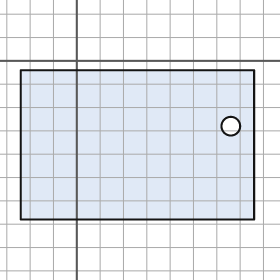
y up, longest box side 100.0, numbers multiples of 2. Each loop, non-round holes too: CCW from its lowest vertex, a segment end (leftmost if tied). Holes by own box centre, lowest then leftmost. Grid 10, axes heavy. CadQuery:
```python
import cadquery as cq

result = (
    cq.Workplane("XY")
    .moveTo(-24.0, -68.0)
    .lineTo(76.0, -68.0)
    .lineTo(76.0, -4.0)
    .lineTo(-24.0, -4.0)
    .close()
    .moveTo(66.0, -28.0)
    .circle(4.0)
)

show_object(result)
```